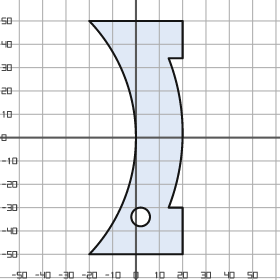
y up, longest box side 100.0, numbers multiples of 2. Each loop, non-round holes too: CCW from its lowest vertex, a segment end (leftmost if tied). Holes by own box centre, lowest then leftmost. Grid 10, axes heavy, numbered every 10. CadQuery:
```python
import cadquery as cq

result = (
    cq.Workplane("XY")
    .moveTo(-20.0, -50.0)
    .lineTo(20.0, -50.0)
    .lineTo(20.0, -30.0)
    .lineTo(14.0, -30.0)
    .threePointArc((20.0, 2.0), (14.0, 34.0))
    .lineTo(20.0, 34.0)
    .lineTo(20.0, 50.0)
    .lineTo(-20.0, 50.0)
    .threePointArc((0.0, 0.0), (-20.0, -50.0))
    .close()
    .moveTo(2.0, -34.0)
    .circle(4.0)
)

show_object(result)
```